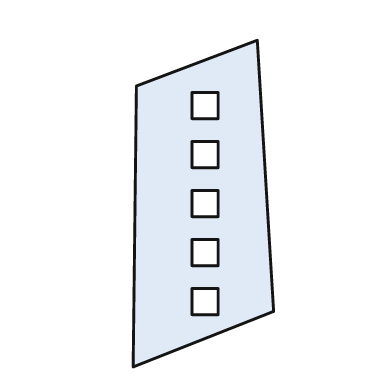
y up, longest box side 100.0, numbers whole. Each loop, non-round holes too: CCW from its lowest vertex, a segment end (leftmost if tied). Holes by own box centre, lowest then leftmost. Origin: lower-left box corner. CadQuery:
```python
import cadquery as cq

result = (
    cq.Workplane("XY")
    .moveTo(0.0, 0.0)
    .lineTo(43.0, 17.0)
    .lineTo(38.0, 100.0)
    .lineTo(1.0, 86.0)
    .close()
    .moveTo(18.0, 16.0)
    .lineTo(26.0, 16.0)
    .lineTo(26.0, 24.0)
    .lineTo(18.0, 24.0)
    .close()
    .moveTo(18.0, 31.0)
    .lineTo(26.0, 31.0)
    .lineTo(26.0, 39.0)
    .lineTo(18.0, 39.0)
    .close()
    .moveTo(18.0, 46.0)
    .lineTo(26.0, 46.0)
    .lineTo(26.0, 54.0)
    .lineTo(18.0, 54.0)
    .close()
    .moveTo(18.0, 61.0)
    .lineTo(26.0, 61.0)
    .lineTo(26.0, 69.0)
    .lineTo(18.0, 69.0)
    .close()
    .moveTo(18.0, 76.0)
    .lineTo(26.0, 76.0)
    .lineTo(26.0, 84.0)
    .lineTo(18.0, 84.0)
    .close()
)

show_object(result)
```